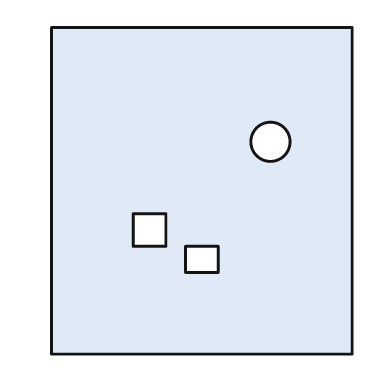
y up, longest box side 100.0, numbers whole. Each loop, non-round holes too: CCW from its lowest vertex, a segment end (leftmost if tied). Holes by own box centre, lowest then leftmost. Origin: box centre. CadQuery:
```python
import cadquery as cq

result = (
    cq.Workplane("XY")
    .moveTo(-46.0, -50.0)
    .lineTo(46.0, -50.0)
    .lineTo(46.0, 50.0)
    .lineTo(-46.0, 50.0)
    .close()
    .moveTo(-5.0, -25.0)
    .lineTo(5.0, -25.0)
    .lineTo(5.0, -17.0)
    .lineTo(-5.0, -17.0)
    .close()
    .moveTo(-21.0, -17.0)
    .lineTo(-11.0, -17.0)
    .lineTo(-11.0, -7.0)
    .lineTo(-21.0, -7.0)
    .close()
    .moveTo(21.0, 15.0)
    .circle(6.0)
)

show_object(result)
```